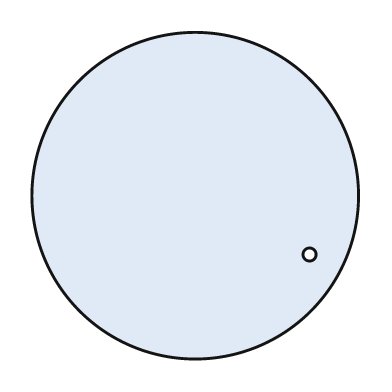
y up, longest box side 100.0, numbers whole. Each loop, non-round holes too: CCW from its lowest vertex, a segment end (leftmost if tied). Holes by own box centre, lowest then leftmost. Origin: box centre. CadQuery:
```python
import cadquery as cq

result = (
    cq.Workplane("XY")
    .moveTo(0.0, 0.0)
    .circle(50.0)
    .moveTo(35.0, -18.0)
    .circle(2.0)
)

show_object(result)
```